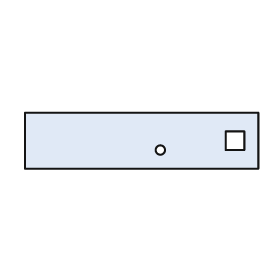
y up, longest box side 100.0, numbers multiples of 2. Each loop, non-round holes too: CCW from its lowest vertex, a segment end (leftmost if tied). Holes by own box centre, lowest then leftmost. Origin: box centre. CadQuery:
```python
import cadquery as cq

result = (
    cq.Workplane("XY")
    .moveTo(-50.0, -12.0)
    .lineTo(50.0, -12.0)
    .lineTo(50.0, 12.0)
    .lineTo(-50.0, 12.0)
    .close()
    .moveTo(8.0, -4.0)
    .circle(2.0)
    .moveTo(36.0, -4.0)
    .lineTo(44.0, -4.0)
    .lineTo(44.0, 4.0)
    .lineTo(36.0, 4.0)
    .close()
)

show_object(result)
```